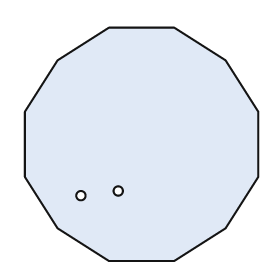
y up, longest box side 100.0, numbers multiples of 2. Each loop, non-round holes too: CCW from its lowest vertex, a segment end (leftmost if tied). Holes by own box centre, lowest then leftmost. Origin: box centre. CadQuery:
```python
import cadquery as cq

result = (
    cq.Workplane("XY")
    .moveTo(-14.0, -50.0)
    .lineTo(14.0, -50.0)
    .lineTo(36.0, -36.0)
    .lineTo(50.0, -14.0)
    .lineTo(50.0, 14.0)
    .lineTo(36.0, 36.0)
    .lineTo(14.0, 50.0)
    .lineTo(-14.0, 50.0)
    .lineTo(-36.0, 36.0)
    .lineTo(-50.0, 14.0)
    .lineTo(-50.0, -14.0)
    .lineTo(-36.0, -36.0)
    .close()
    .moveTo(-26.0, -22.0)
    .circle(2.0)
    .moveTo(-10.0, -20.0)
    .circle(2.0)
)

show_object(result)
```